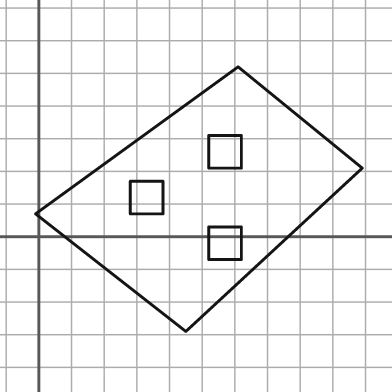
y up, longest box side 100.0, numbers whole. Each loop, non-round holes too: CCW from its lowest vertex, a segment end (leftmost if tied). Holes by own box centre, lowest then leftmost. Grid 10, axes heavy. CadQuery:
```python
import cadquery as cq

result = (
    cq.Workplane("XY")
    .moveTo(45.0, -29.0)
    .lineTo(99.0, 21.0)
    .lineTo(61.0, 52.0)
    .lineTo(-1.0, 7.0)
    .close()
    .moveTo(52.0, -7.0)
    .lineTo(62.0, -7.0)
    .lineTo(62.0, 3.0)
    .lineTo(52.0, 3.0)
    .close()
    .moveTo(28.0, 7.0)
    .lineTo(38.0, 7.0)
    .lineTo(38.0, 17.0)
    .lineTo(28.0, 17.0)
    .close()
    .moveTo(52.0, 21.0)
    .lineTo(62.0, 21.0)
    .lineTo(62.0, 31.0)
    .lineTo(52.0, 31.0)
    .close()
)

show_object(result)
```